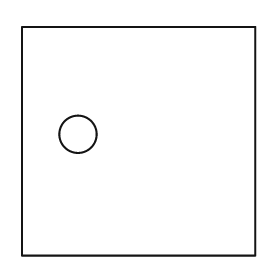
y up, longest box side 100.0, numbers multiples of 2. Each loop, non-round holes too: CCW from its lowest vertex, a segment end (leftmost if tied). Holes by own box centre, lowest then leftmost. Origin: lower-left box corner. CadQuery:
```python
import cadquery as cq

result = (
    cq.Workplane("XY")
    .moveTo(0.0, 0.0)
    .lineTo(100.0, 0.0)
    .lineTo(100.0, 98.0)
    .lineTo(0.0, 98.0)
    .close()
    .moveTo(24.0, 52.0)
    .circle(8.0)
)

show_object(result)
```